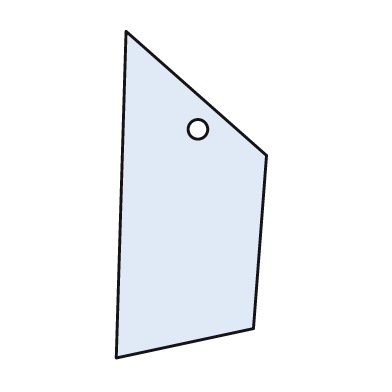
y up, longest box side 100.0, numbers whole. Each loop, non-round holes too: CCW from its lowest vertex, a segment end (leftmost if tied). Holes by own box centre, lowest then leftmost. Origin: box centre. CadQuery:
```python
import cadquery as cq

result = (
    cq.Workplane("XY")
    .moveTo(-23.0, -50.0)
    .lineTo(19.0, -41.0)
    .lineTo(23.0, 12.0)
    .lineTo(-20.0, 50.0)
    .close()
    .moveTo(2.0, 20.0)
    .circle(3.0)
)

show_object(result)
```